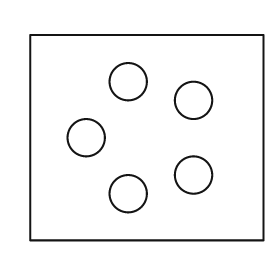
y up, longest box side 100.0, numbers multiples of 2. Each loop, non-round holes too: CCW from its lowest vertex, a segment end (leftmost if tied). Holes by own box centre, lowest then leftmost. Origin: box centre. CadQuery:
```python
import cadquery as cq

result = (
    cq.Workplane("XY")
    .moveTo(-50.0, -44.0)
    .lineTo(50.0, -44.0)
    .lineTo(50.0, 44.0)
    .lineTo(-50.0, 44.0)
    .close()
    .moveTo(-8.0, -24.0)
    .circle(8.0)
    .moveTo(20.0, -16.0)
    .circle(8.0)
    .moveTo(-26.0, 0.0)
    .circle(8.0)
    .moveTo(20.0, 16.0)
    .circle(8.0)
    .moveTo(-8.0, 24.0)
    .circle(8.0)
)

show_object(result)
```